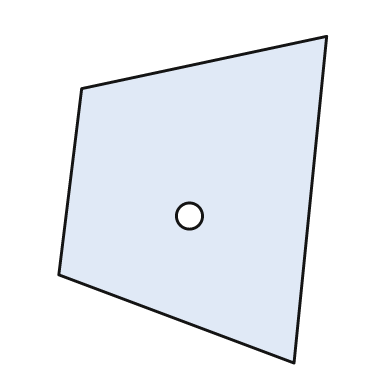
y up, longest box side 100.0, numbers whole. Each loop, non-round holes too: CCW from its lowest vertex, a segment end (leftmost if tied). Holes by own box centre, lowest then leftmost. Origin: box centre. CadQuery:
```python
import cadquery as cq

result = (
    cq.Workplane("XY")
    .moveTo(31.0, -50.0)
    .lineTo(41.0, 50.0)
    .lineTo(-34.0, 34.0)
    .lineTo(-41.0, -23.0)
    .close()
    .moveTo(-1.0, -5.0)
    .circle(4.0)
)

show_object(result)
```